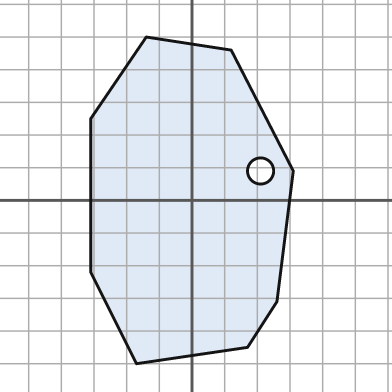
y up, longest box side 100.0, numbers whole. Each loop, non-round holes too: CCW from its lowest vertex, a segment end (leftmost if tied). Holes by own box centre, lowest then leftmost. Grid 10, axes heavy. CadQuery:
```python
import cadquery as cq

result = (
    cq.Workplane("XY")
    .moveTo(-17.0, -50.0)
    .lineTo(17.0, -45.0)
    .lineTo(26.0, -31.0)
    .lineTo(31.0, 9.0)
    .lineTo(12.0, 46.0)
    .lineTo(-14.0, 50.0)
    .lineTo(-31.0, 25.0)
    .lineTo(-31.0, -22.0)
    .close()
    .moveTo(21.0, 9.0)
    .circle(4.0)
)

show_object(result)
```